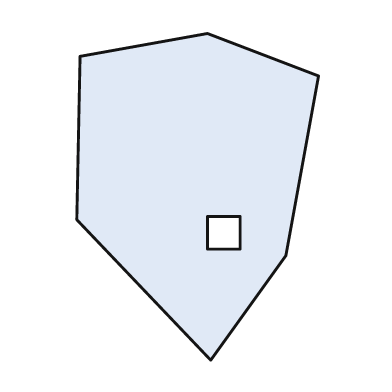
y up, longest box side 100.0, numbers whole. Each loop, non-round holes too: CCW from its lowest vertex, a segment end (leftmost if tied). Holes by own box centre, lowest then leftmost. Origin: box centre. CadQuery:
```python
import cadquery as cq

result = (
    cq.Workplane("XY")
    .moveTo(4.0, -50.0)
    .lineTo(27.0, -18.0)
    .lineTo(37.0, 37.0)
    .lineTo(3.0, 50.0)
    .lineTo(-36.0, 43.0)
    .lineTo(-37.0, -7.0)
    .close()
    .moveTo(3.0, -16.0)
    .lineTo(13.0, -16.0)
    .lineTo(13.0, -6.0)
    .lineTo(3.0, -6.0)
    .close()
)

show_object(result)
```